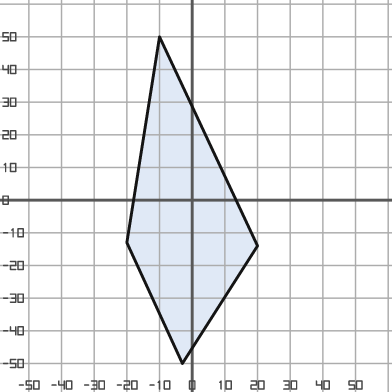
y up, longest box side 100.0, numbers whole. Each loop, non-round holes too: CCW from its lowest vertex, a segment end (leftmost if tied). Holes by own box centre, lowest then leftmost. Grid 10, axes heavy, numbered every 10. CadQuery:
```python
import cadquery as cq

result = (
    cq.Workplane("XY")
    .moveTo(-3.0, -50.0)
    .lineTo(20.0, -14.0)
    .lineTo(-10.0, 50.0)
    .lineTo(-20.0, -13.0)
    .close()
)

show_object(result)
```